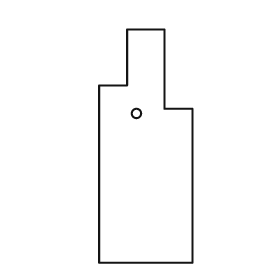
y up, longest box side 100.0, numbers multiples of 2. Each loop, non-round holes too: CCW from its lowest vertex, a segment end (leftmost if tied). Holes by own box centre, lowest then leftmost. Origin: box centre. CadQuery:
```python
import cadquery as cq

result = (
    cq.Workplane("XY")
    .moveTo(-20.0, -50.0)
    .lineTo(20.0, -50.0)
    .lineTo(20.0, 16.0)
    .lineTo(8.0, 16.0)
    .lineTo(8.0, 50.0)
    .lineTo(-8.0, 50.0)
    .lineTo(-8.0, 26.0)
    .lineTo(-20.0, 26.0)
    .close()
    .moveTo(-4.0, 14.0)
    .circle(2.0)
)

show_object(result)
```